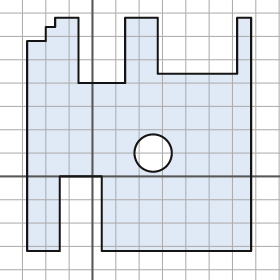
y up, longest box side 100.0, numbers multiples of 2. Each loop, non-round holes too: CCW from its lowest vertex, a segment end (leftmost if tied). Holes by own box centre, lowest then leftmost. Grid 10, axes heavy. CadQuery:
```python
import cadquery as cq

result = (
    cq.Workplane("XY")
    .moveTo(-28.0, -32.0)
    .lineTo(-14.0, -32.0)
    .lineTo(-14.0, 0.0)
    .lineTo(4.0, 0.0)
    .lineTo(4.0, -32.0)
    .lineTo(68.0, -32.0)
    .lineTo(68.0, 68.0)
    .lineTo(62.0, 68.0)
    .lineTo(62.0, 44.0)
    .lineTo(28.0, 44.0)
    .lineTo(28.0, 68.0)
    .lineTo(14.0, 68.0)
    .lineTo(14.0, 40.0)
    .lineTo(-6.0, 40.0)
    .lineTo(-6.0, 68.0)
    .lineTo(-16.0, 68.0)
    .lineTo(-16.0, 64.0)
    .lineTo(-20.0, 64.0)
    .lineTo(-20.0, 58.0)
    .lineTo(-28.0, 58.0)
    .close()
    .moveTo(26.0, 10.0)
    .circle(8.0)
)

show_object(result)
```